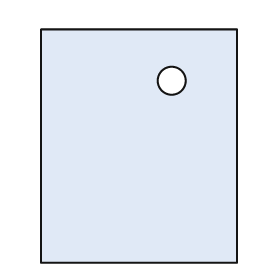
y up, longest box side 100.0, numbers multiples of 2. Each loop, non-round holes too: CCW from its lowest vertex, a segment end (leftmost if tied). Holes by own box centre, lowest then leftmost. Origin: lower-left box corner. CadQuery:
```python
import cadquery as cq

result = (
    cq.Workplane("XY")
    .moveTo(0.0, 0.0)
    .lineTo(84.0, 0.0)
    .lineTo(84.0, 100.0)
    .lineTo(0.0, 100.0)
    .close()
    .moveTo(56.0, 78.0)
    .circle(6.0)
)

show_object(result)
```